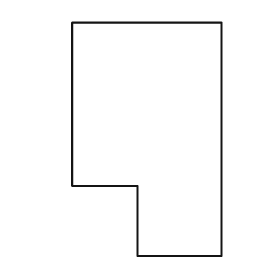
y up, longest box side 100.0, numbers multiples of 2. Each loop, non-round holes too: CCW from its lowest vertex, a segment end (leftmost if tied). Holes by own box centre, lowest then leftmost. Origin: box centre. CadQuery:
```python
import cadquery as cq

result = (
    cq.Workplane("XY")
    .moveTo(-4.0, -50.0)
    .lineTo(32.0, -50.0)
    .lineTo(32.0, 50.0)
    .lineTo(-32.0, 50.0)
    .lineTo(-32.0, -20.0)
    .lineTo(-4.0, -20.0)
    .close()
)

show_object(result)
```